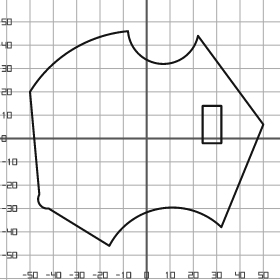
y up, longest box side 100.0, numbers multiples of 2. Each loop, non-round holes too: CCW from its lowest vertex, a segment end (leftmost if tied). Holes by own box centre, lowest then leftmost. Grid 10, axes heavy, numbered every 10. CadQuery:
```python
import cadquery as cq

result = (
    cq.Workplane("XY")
    .moveTo(-16.0, -46.0)
    .threePointArc((6.0, -30.0), (32.0, -38.0))
    .lineTo(50.0, 6.0)
    .lineTo(22.0, 44.0)
    .threePointArc((6.0, 32.0), (-8.0, 46.0))
    .threePointArc((-32.0, 38.0), (-50.0, 20.0))
    .lineTo(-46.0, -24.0)
    .threePointArc((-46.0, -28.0), (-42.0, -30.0))
    .close()
    .moveTo(24.0, -2.0)
    .lineTo(32.0, -2.0)
    .lineTo(32.0, 14.0)
    .lineTo(24.0, 14.0)
    .close()
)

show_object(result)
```